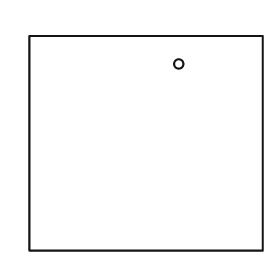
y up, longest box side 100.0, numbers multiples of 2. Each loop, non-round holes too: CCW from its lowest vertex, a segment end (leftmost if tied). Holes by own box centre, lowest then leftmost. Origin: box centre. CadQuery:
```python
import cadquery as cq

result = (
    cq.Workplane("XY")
    .moveTo(-50.0, -46.0)
    .lineTo(50.0, -46.0)
    .lineTo(50.0, 46.0)
    .lineTo(-50.0, 46.0)
    .close()
    .moveTo(14.0, 34.0)
    .circle(2.0)
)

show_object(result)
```